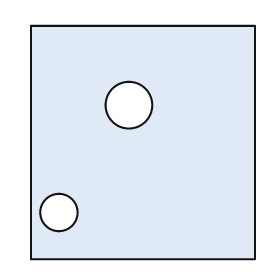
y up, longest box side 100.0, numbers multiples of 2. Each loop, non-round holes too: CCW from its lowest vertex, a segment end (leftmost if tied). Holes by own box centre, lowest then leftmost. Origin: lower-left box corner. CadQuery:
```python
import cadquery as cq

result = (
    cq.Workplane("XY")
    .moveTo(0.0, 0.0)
    .lineTo(96.0, 0.0)
    .lineTo(96.0, 100.0)
    .lineTo(0.0, 100.0)
    .close()
    .moveTo(12.0, 20.0)
    .circle(8.0)
    .moveTo(42.0, 66.0)
    .circle(10.0)
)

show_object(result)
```